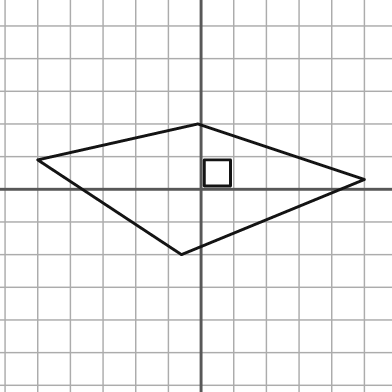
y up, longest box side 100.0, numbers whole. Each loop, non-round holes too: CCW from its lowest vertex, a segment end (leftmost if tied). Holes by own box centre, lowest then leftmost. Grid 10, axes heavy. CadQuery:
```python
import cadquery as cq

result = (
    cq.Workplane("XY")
    .moveTo(-6.0, -20.0)
    .lineTo(50.0, 3.0)
    .lineTo(-1.0, 20.0)
    .lineTo(-50.0, 9.0)
    .close()
    .moveTo(1.0, 1.0)
    .lineTo(9.0, 1.0)
    .lineTo(9.0, 9.0)
    .lineTo(1.0, 9.0)
    .close()
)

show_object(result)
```